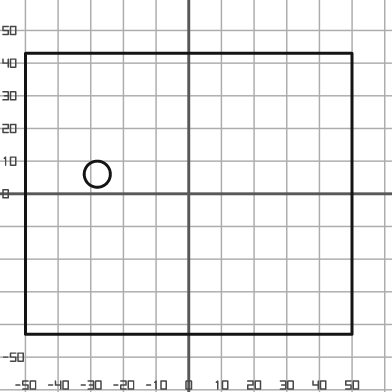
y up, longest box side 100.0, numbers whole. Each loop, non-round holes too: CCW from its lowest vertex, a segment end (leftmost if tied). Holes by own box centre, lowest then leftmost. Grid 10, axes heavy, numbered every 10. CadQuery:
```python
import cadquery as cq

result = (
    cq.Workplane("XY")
    .moveTo(-50.0, -43.0)
    .lineTo(50.0, -43.0)
    .lineTo(50.0, 43.0)
    .lineTo(-50.0, 43.0)
    .close()
    .moveTo(-28.0, 6.0)
    .circle(4.0)
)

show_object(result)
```